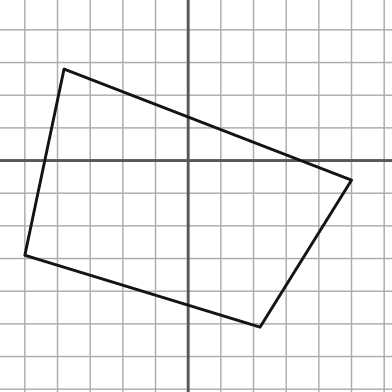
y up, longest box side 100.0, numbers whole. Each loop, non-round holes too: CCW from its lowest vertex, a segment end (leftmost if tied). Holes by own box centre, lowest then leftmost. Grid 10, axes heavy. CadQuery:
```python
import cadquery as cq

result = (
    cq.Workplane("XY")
    .moveTo(22.0, -51.0)
    .lineTo(50.0, -6.0)
    .lineTo(-38.0, 28.0)
    .lineTo(-50.0, -29.0)
    .close()
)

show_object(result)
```